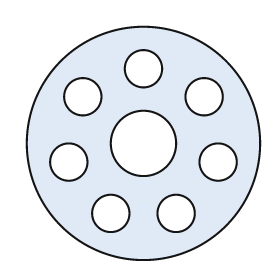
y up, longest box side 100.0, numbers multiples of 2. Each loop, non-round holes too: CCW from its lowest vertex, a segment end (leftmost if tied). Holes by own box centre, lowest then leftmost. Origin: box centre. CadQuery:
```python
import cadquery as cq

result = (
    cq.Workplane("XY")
    .moveTo(0.0, 0.0)
    .circle(50.0)
    .moveTo(-14.0, -30.0)
    .circle(8.0)
    .moveTo(14.0, -30.0)
    .circle(8.0)
    .moveTo(-32.0, -8.0)
    .circle(8.0)
    .moveTo(32.0, -8.0)
    .circle(8.0)
    .moveTo(0.0, 0.0)
    .circle(14.0)
    .moveTo(-26.0, 20.0)
    .circle(8.0)
    .moveTo(26.0, 20.0)
    .circle(8.0)
    .moveTo(0.0, 32.0)
    .circle(8.0)
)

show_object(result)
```